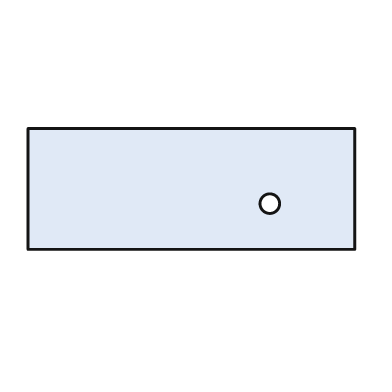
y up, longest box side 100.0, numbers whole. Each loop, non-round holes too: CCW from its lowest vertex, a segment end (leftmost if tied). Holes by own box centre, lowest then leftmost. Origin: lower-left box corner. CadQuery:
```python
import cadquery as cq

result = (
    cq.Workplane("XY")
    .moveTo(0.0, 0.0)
    .lineTo(100.0, 0.0)
    .lineTo(100.0, 37.0)
    .lineTo(0.0, 37.0)
    .close()
    .moveTo(74.0, 14.0)
    .circle(3.0)
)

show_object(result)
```